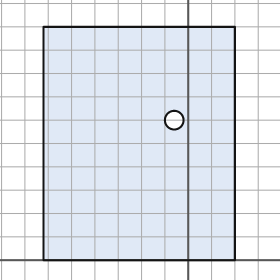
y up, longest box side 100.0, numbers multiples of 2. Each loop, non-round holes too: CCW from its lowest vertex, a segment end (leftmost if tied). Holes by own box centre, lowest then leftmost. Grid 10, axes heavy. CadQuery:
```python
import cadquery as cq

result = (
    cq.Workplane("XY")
    .moveTo(-62.0, 0.0)
    .lineTo(20.0, 0.0)
    .lineTo(20.0, 100.0)
    .lineTo(-62.0, 100.0)
    .close()
    .moveTo(-6.0, 60.0)
    .circle(4.0)
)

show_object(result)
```